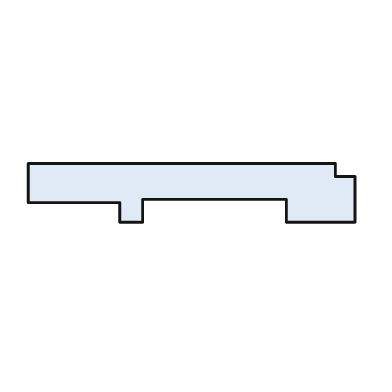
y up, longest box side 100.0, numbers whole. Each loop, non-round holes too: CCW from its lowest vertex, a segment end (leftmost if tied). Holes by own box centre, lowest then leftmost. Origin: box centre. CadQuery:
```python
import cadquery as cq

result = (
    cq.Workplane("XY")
    .moveTo(-22.0, -9.0)
    .lineTo(-15.0, -9.0)
    .lineTo(-15.0, -2.0)
    .lineTo(29.0, -2.0)
    .lineTo(29.0, -9.0)
    .lineTo(50.0, -9.0)
    .lineTo(50.0, 5.0)
    .lineTo(44.0, 5.0)
    .lineTo(44.0, 9.0)
    .lineTo(-50.0, 9.0)
    .lineTo(-50.0, -3.0)
    .lineTo(-22.0, -3.0)
    .close()
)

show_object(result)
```